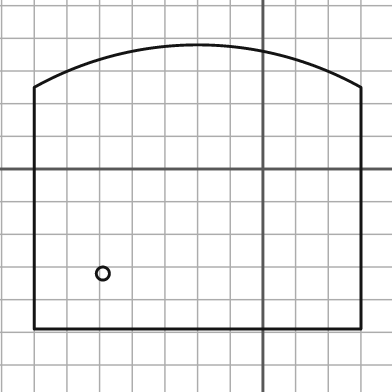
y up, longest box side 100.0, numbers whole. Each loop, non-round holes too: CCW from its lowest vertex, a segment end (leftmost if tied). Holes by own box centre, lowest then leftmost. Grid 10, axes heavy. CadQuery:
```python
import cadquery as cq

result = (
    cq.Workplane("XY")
    .moveTo(-70.0, -49.0)
    .lineTo(30.0, -49.0)
    .lineTo(30.0, 25.0)
    .threePointArc((-20.0, 38.0), (-70.0, 25.0))
    .close()
    .moveTo(-49.0, -32.0)
    .circle(2.0)
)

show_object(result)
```